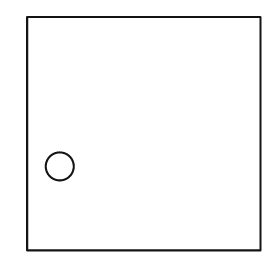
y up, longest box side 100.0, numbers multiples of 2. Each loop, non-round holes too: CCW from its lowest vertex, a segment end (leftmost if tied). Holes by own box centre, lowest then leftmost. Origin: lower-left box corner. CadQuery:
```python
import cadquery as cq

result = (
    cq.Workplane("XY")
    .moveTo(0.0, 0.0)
    .lineTo(100.0, 0.0)
    .lineTo(100.0, 100.0)
    .lineTo(0.0, 100.0)
    .close()
    .moveTo(14.0, 36.0)
    .circle(6.0)
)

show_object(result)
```